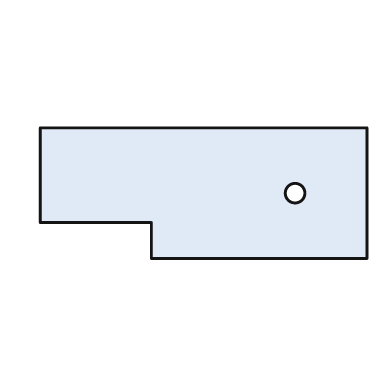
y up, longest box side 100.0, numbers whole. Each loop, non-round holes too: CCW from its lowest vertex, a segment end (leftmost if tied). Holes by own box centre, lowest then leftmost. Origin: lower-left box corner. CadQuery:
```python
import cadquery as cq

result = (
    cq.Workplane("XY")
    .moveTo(34.0, 0.0)
    .lineTo(100.0, 0.0)
    .lineTo(100.0, 40.0)
    .lineTo(0.0, 40.0)
    .lineTo(0.0, 11.0)
    .lineTo(34.0, 11.0)
    .close()
    .moveTo(78.0, 20.0)
    .circle(3.0)
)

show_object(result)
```